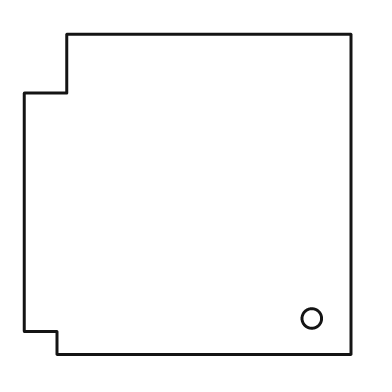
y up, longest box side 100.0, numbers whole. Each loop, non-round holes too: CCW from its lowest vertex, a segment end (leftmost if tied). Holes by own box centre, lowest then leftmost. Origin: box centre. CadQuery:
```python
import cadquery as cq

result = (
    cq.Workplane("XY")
    .moveTo(-40.0, -49.0)
    .lineTo(50.0, -49.0)
    .lineTo(50.0, 49.0)
    .lineTo(-37.0, 49.0)
    .lineTo(-37.0, 31.0)
    .lineTo(-50.0, 31.0)
    .lineTo(-50.0, -42.0)
    .lineTo(-40.0, -42.0)
    .close()
    .moveTo(38.0, -38.0)
    .circle(3.0)
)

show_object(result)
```